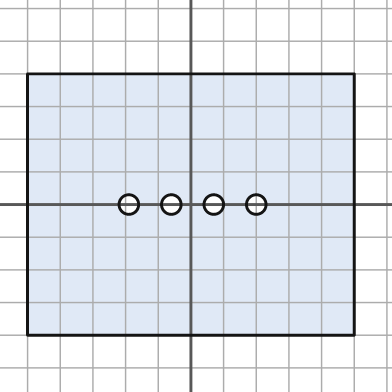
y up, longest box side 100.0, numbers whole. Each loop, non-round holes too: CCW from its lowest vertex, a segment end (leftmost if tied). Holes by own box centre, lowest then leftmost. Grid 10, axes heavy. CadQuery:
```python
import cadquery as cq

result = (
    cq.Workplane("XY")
    .moveTo(-50.0, -40.0)
    .lineTo(50.0, -40.0)
    .lineTo(50.0, 40.0)
    .lineTo(-50.0, 40.0)
    .close()
    .moveTo(-19.0, 0.0)
    .circle(3.0)
    .moveTo(-6.0, 0.0)
    .circle(3.0)
    .moveTo(7.0, 0.0)
    .circle(3.0)
    .moveTo(20.0, 0.0)
    .circle(3.0)
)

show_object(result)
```